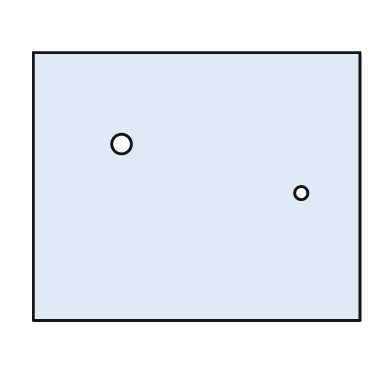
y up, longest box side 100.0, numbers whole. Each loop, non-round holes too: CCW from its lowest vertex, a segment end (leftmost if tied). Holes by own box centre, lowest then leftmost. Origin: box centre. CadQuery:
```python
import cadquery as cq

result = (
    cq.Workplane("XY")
    .moveTo(-50.0, -41.0)
    .lineTo(50.0, -41.0)
    .lineTo(50.0, 41.0)
    .lineTo(-50.0, 41.0)
    .close()
    .moveTo(32.0, -2.0)
    .circle(2.0)
    .moveTo(-23.0, 13.0)
    .circle(3.0)
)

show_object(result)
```